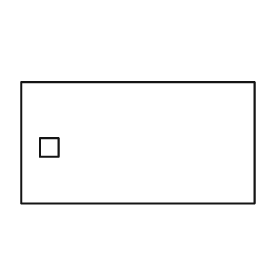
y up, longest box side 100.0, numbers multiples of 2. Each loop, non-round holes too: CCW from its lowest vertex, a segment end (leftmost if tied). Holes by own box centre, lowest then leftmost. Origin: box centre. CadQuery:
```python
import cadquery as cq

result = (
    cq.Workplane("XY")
    .moveTo(-50.0, -26.0)
    .lineTo(50.0, -26.0)
    .lineTo(50.0, 26.0)
    .lineTo(-50.0, 26.0)
    .close()
    .moveTo(-42.0, -6.0)
    .lineTo(-34.0, -6.0)
    .lineTo(-34.0, 2.0)
    .lineTo(-42.0, 2.0)
    .close()
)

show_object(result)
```